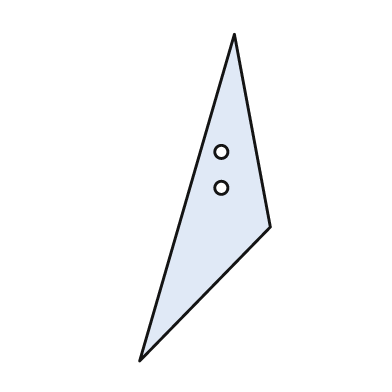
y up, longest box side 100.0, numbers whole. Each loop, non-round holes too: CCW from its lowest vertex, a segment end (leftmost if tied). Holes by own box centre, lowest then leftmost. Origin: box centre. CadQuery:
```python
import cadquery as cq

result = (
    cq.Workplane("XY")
    .moveTo(-20.0, -50.0)
    .lineTo(20.0, -9.0)
    .lineTo(9.0, 50.0)
    .close()
    .moveTo(5.0, 3.0)
    .circle(2.0)
    .moveTo(5.0, 14.0)
    .circle(2.0)
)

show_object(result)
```